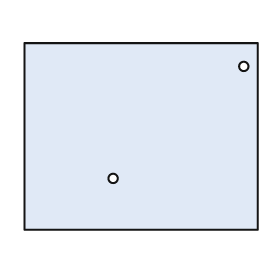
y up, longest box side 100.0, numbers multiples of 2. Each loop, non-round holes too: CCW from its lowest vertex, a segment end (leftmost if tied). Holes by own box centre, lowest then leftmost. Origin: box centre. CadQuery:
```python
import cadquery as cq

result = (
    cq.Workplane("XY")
    .moveTo(-50.0, -40.0)
    .lineTo(50.0, -40.0)
    .lineTo(50.0, 40.0)
    .lineTo(-50.0, 40.0)
    .close()
    .moveTo(-12.0, -18.0)
    .circle(2.0)
    .moveTo(44.0, 30.0)
    .circle(2.0)
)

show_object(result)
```